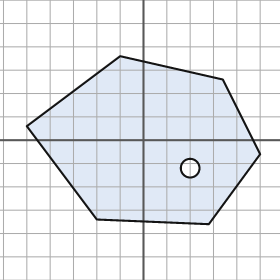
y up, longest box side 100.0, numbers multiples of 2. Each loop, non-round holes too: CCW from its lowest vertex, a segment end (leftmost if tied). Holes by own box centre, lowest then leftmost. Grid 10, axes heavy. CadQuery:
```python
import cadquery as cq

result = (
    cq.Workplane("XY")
    .moveTo(28.0, -36.0)
    .lineTo(50.0, -6.0)
    .lineTo(34.0, 26.0)
    .lineTo(-10.0, 36.0)
    .lineTo(-50.0, 6.0)
    .lineTo(-20.0, -34.0)
    .close()
    .moveTo(20.0, -12.0)
    .circle(4.0)
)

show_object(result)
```